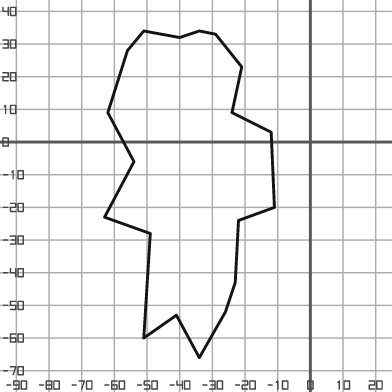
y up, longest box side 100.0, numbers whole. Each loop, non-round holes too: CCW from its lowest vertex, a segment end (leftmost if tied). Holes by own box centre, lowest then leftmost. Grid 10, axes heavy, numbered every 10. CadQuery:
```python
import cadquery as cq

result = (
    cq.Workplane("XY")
    .moveTo(-34.0, -66.0)
    .lineTo(-26.0, -52.0)
    .lineTo(-23.0, -43.0)
    .lineTo(-22.0, -24.0)
    .lineTo(-11.0, -20.0)
    .lineTo(-12.0, 3.0)
    .lineTo(-24.0, 9.0)
    .lineTo(-21.0, 23.0)
    .lineTo(-29.0, 33.0)
    .lineTo(-34.0, 34.0)
    .lineTo(-40.0, 32.0)
    .lineTo(-51.0, 34.0)
    .lineTo(-56.0, 28.0)
    .lineTo(-62.0, 9.0)
    .lineTo(-54.0, -6.0)
    .lineTo(-63.0, -23.0)
    .lineTo(-49.0, -28.0)
    .lineTo(-51.0, -60.0)
    .lineTo(-41.0, -53.0)
    .close()
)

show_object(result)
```